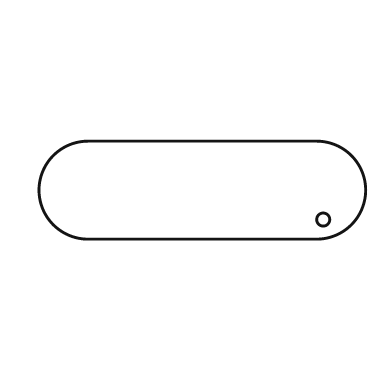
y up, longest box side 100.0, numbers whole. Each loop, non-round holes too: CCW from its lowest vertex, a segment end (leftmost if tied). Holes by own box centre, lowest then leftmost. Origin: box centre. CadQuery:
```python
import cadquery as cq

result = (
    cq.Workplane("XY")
    .moveTo(-35.0, -15.0)
    .lineTo(35.0, -15.0)
    .threePointArc((50.0, 0.0), (35.0, 15.0))
    .lineTo(-35.0, 15.0)
    .threePointArc((-50.0, 0.0), (-35.0, -15.0))
    .close()
    .moveTo(37.0, -9.0)
    .circle(2.0)
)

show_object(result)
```